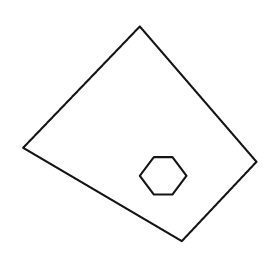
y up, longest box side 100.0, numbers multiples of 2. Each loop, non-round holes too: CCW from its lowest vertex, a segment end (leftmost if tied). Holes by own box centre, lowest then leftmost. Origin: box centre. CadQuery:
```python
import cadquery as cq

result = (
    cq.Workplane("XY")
    .moveTo(18.0, -46.0)
    .lineTo(50.0, -12.0)
    .lineTo(0.0, 46.0)
    .lineTo(-50.0, -6.0)
    .close()
    .moveTo(6.0, -26.0)
    .lineTo(14.0, -26.0)
    .lineTo(20.0, -18.0)
    .lineTo(14.0, -10.0)
    .lineTo(6.0, -10.0)
    .lineTo(0.0, -18.0)
    .close()
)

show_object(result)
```